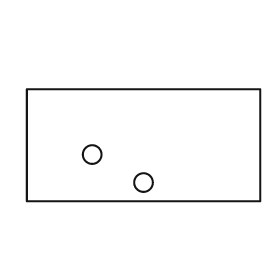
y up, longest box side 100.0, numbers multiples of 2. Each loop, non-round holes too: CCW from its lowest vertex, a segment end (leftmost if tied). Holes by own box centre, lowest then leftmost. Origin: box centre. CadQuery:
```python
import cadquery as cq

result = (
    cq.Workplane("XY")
    .moveTo(-50.0, -24.0)
    .lineTo(50.0, -24.0)
    .lineTo(50.0, 24.0)
    .lineTo(-50.0, 24.0)
    .close()
    .moveTo(0.0, -16.0)
    .circle(4.0)
    .moveTo(-22.0, -4.0)
    .circle(4.0)
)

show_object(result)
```